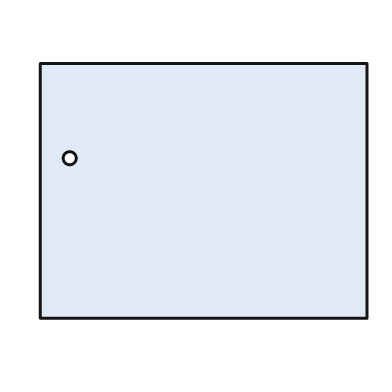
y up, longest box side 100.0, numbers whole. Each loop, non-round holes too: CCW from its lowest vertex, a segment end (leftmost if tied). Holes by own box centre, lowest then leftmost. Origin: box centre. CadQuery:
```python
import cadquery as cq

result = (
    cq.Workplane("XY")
    .moveTo(-50.0, -39.0)
    .lineTo(50.0, -39.0)
    .lineTo(50.0, 39.0)
    .lineTo(-50.0, 39.0)
    .close()
    .moveTo(-41.0, 10.0)
    .circle(2.0)
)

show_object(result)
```